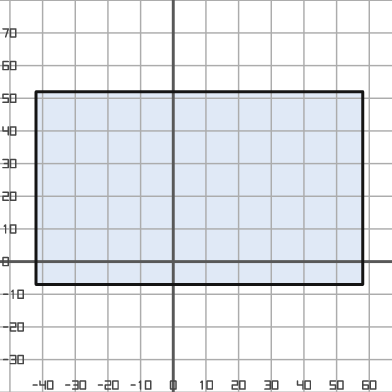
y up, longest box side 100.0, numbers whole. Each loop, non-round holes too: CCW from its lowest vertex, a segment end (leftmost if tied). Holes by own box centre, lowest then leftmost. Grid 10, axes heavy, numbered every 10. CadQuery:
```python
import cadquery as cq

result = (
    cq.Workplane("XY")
    .moveTo(-42.0, -7.0)
    .lineTo(58.0, -7.0)
    .lineTo(58.0, 52.0)
    .lineTo(-42.0, 52.0)
    .close()
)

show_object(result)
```